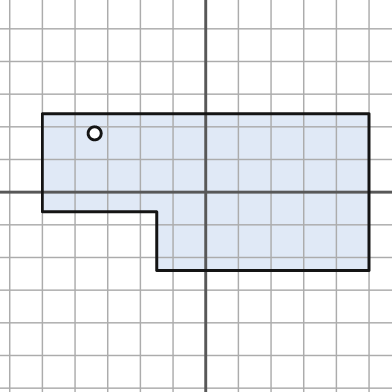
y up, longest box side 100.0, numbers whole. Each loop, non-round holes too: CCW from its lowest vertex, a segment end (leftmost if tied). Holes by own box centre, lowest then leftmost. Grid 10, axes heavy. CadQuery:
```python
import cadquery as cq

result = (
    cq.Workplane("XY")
    .moveTo(-15.0, -24.0)
    .lineTo(50.0, -24.0)
    .lineTo(50.0, 24.0)
    .lineTo(-50.0, 24.0)
    .lineTo(-50.0, -6.0)
    .lineTo(-15.0, -6.0)
    .close()
    .moveTo(-34.0, 18.0)
    .circle(2.0)
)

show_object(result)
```